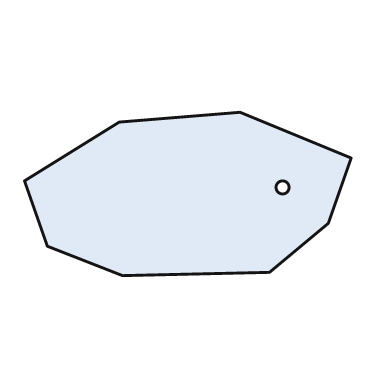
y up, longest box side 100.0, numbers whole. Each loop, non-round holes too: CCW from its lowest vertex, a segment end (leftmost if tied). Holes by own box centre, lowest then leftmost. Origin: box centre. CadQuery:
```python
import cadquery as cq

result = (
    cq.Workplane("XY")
    .moveTo(-20.0, -25.0)
    .lineTo(25.0, -24.0)
    .lineTo(43.0, -9.0)
    .lineTo(50.0, 11.0)
    .lineTo(16.0, 25.0)
    .lineTo(-21.0, 22.0)
    .lineTo(-50.0, 4.0)
    .lineTo(-43.0, -16.0)
    .close()
    .moveTo(29.0, 2.0)
    .circle(2.0)
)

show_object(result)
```